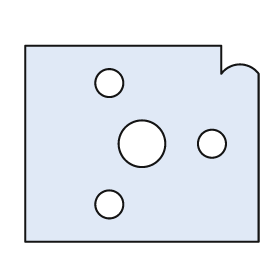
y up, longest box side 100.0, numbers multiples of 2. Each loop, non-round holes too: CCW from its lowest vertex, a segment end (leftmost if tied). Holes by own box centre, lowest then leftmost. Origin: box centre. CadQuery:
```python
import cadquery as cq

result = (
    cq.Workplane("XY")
    .moveTo(-50.0, -42.0)
    .lineTo(50.0, -42.0)
    .lineTo(50.0, 30.0)
    .threePointArc((42.0, 34.0), (34.0, 30.0))
    .lineTo(34.0, 42.0)
    .lineTo(-50.0, 42.0)
    .close()
    .moveTo(-14.0, -26.0)
    .circle(6.0)
    .moveTo(0.0, 0.0)
    .circle(10.0)
    .moveTo(30.0, 0.0)
    .circle(6.0)
    .moveTo(-14.0, 26.0)
    .circle(6.0)
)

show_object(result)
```